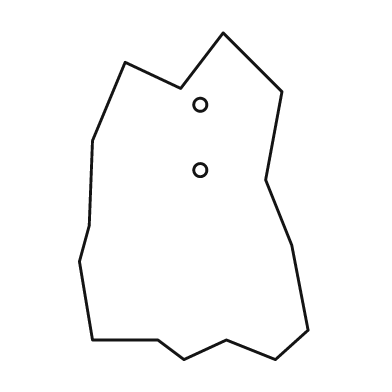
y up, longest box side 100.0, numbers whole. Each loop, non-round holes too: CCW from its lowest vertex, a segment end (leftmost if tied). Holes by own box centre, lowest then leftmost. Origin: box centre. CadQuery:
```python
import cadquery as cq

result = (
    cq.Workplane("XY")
    .moveTo(-3.0, -50.0)
    .lineTo(10.0, -44.0)
    .lineTo(25.0, -50.0)
    .lineTo(35.0, -41.0)
    .lineTo(30.0, -15.0)
    .lineTo(22.0, 5.0)
    .lineTo(27.0, 32.0)
    .lineTo(9.0, 50.0)
    .lineTo(-4.0, 33.0)
    .lineTo(-21.0, 41.0)
    .lineTo(-31.0, 17.0)
    .lineTo(-32.0, -9.0)
    .lineTo(-35.0, -20.0)
    .lineTo(-31.0, -44.0)
    .lineTo(-11.0, -44.0)
    .close()
    .moveTo(2.0, 8.0)
    .circle(2.0)
    .moveTo(2.0, 28.0)
    .circle(2.0)
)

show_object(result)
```